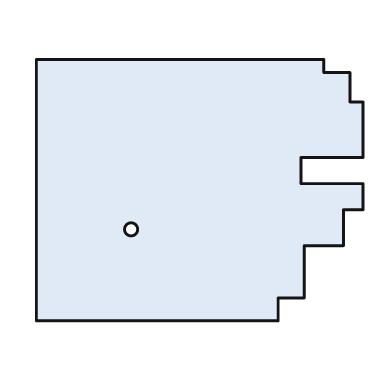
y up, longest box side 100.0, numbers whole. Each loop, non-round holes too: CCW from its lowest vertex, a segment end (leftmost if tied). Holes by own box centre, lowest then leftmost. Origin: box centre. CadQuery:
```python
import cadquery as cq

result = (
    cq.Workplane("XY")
    .moveTo(-50.0, -40.0)
    .lineTo(24.0, -40.0)
    .lineTo(24.0, -33.0)
    .lineTo(32.0, -33.0)
    .lineTo(32.0, -17.0)
    .lineTo(44.0, -17.0)
    .lineTo(44.0, -6.0)
    .lineTo(50.0, -6.0)
    .lineTo(50.0, 2.0)
    .lineTo(31.0, 2.0)
    .lineTo(31.0, 10.0)
    .lineTo(50.0, 10.0)
    .lineTo(50.0, 27.0)
    .lineTo(46.0, 27.0)
    .lineTo(46.0, 36.0)
    .lineTo(38.0, 36.0)
    .lineTo(38.0, 40.0)
    .lineTo(-50.0, 40.0)
    .close()
    .moveTo(-21.0, -12.0)
    .circle(2.0)
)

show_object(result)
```